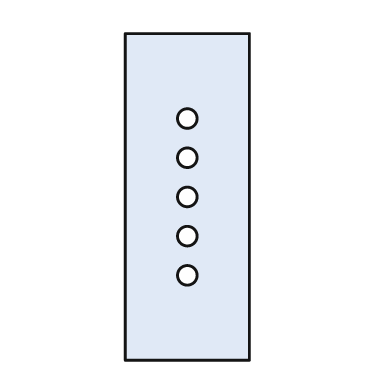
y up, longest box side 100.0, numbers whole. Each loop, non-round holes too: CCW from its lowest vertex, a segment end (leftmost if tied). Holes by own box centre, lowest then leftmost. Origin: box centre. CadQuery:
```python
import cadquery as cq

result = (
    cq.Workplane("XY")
    .moveTo(-19.0, -50.0)
    .lineTo(19.0, -50.0)
    .lineTo(19.0, 50.0)
    .lineTo(-19.0, 50.0)
    .close()
    .moveTo(0.0, -24.0)
    .circle(3.0)
    .moveTo(0.0, -12.0)
    .circle(3.0)
    .moveTo(0.0, 0.0)
    .circle(3.0)
    .moveTo(0.0, 12.0)
    .circle(3.0)
    .moveTo(0.0, 24.0)
    .circle(3.0)
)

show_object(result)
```